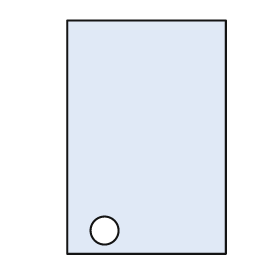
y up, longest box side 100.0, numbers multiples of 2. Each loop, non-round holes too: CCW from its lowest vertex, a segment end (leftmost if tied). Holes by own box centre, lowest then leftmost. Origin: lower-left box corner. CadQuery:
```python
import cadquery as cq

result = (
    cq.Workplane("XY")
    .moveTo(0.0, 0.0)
    .lineTo(68.0, 0.0)
    .lineTo(68.0, 100.0)
    .lineTo(0.0, 100.0)
    .close()
    .moveTo(16.0, 10.0)
    .circle(6.0)
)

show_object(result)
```